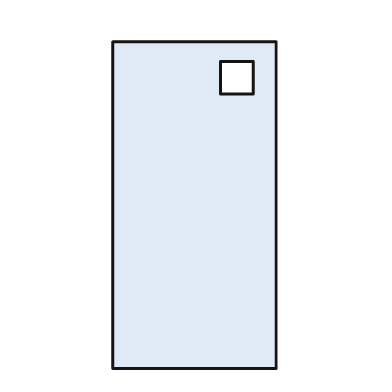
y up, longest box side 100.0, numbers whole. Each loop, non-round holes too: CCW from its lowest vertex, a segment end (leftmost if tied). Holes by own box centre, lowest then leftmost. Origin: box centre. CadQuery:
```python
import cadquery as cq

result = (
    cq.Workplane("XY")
    .moveTo(-25.0, -50.0)
    .lineTo(25.0, -50.0)
    .lineTo(25.0, 50.0)
    .lineTo(-25.0, 50.0)
    .close()
    .moveTo(8.0, 34.0)
    .lineTo(18.0, 34.0)
    .lineTo(18.0, 44.0)
    .lineTo(8.0, 44.0)
    .close()
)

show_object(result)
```